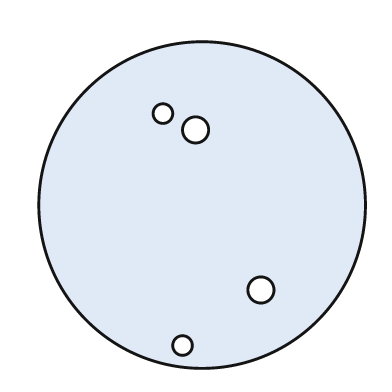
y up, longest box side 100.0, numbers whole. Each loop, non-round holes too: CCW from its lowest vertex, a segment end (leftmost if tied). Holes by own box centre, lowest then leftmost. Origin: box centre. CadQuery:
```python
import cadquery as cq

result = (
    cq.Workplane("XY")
    .moveTo(0.0, 0.0)
    .circle(50.0)
    .moveTo(-6.0, -43.0)
    .circle(3.0)
    .moveTo(18.0, -26.0)
    .circle(4.0)
    .moveTo(-2.0, 23.0)
    .circle(4.0)
    .moveTo(-12.0, 28.0)
    .circle(3.0)
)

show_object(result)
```